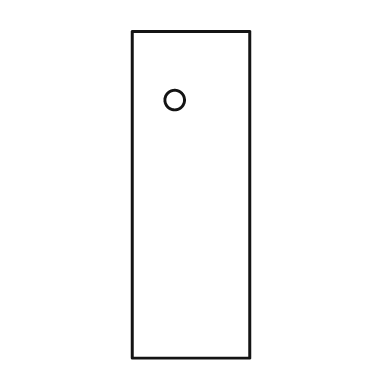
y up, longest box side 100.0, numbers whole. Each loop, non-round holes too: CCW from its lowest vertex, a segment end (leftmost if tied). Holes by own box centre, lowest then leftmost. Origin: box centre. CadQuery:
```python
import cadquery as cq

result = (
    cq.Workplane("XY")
    .moveTo(-18.0, -50.0)
    .lineTo(18.0, -50.0)
    .lineTo(18.0, 50.0)
    .lineTo(-18.0, 50.0)
    .close()
    .moveTo(-5.0, 29.0)
    .circle(3.0)
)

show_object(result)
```